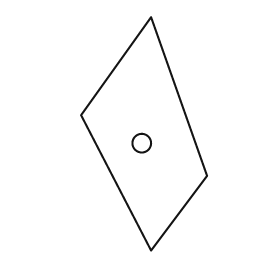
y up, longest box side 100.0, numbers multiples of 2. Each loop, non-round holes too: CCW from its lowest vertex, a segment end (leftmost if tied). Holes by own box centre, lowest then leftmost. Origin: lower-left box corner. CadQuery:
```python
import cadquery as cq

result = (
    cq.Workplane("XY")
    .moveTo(30.0, 0.0)
    .lineTo(54.0, 32.0)
    .lineTo(30.0, 100.0)
    .lineTo(0.0, 58.0)
    .close()
    .moveTo(26.0, 46.0)
    .circle(4.0)
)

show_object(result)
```